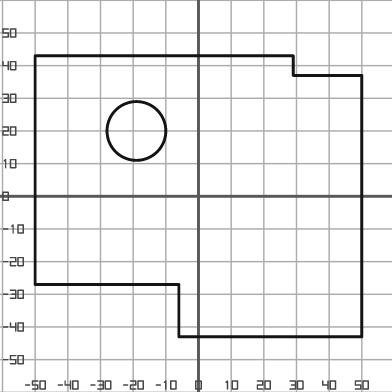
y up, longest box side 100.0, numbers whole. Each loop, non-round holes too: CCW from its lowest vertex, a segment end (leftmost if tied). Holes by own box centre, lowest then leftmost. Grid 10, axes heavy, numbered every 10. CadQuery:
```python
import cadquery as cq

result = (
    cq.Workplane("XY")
    .moveTo(-6.0, -43.0)
    .lineTo(50.0, -43.0)
    .lineTo(50.0, 37.0)
    .lineTo(29.0, 37.0)
    .lineTo(29.0, 43.0)
    .lineTo(-50.0, 43.0)
    .lineTo(-50.0, -27.0)
    .lineTo(-6.0, -27.0)
    .close()
    .moveTo(-19.0, 20.0)
    .circle(9.0)
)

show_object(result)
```